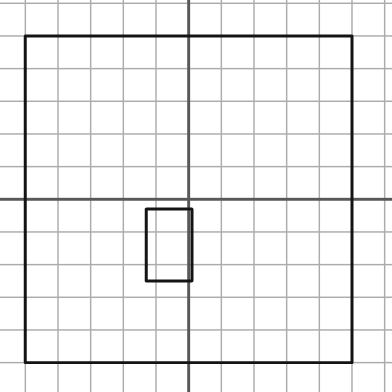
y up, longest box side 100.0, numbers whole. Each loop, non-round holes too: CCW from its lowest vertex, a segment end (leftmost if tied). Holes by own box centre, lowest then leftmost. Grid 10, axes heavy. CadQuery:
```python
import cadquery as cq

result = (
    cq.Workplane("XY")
    .moveTo(-50.0, -50.0)
    .lineTo(50.0, -50.0)
    .lineTo(50.0, 50.0)
    .lineTo(-50.0, 50.0)
    .close()
    .moveTo(-13.0, -25.0)
    .lineTo(1.0, -25.0)
    .lineTo(1.0, -3.0)
    .lineTo(-13.0, -3.0)
    .close()
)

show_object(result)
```